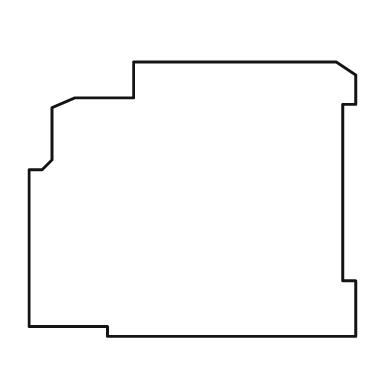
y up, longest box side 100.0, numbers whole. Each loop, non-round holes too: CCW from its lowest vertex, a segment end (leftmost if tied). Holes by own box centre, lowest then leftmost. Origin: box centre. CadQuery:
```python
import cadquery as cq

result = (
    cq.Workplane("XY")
    .moveTo(-26.0, -42.0)
    .lineTo(50.0, -42.0)
    .lineTo(50.0, -25.0)
    .lineTo(46.0, -25.0)
    .lineTo(46.0, 29.0)
    .lineTo(50.0, 29.0)
    .lineTo(50.0, 38.0)
    .lineTo(44.0, 42.0)
    .lineTo(-18.0, 42.0)
    .lineTo(-18.0, 31.0)
    .lineTo(-36.0, 31.0)
    .lineTo(-43.0, 28.0)
    .lineTo(-43.0, 12.0)
    .lineTo(-46.0, 9.0)
    .lineTo(-50.0, 9.0)
    .lineTo(-50.0, -39.0)
    .lineTo(-26.0, -39.0)
    .close()
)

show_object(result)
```